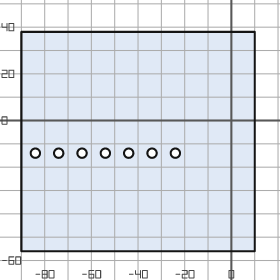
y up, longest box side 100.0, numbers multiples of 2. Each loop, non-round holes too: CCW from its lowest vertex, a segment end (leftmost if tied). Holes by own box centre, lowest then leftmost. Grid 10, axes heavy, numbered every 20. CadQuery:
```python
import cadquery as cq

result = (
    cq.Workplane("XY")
    .moveTo(-90.0, -56.0)
    .lineTo(10.0, -56.0)
    .lineTo(10.0, 38.0)
    .lineTo(-90.0, 38.0)
    .close()
    .moveTo(-84.0, -14.0)
    .circle(2.0)
    .moveTo(-74.0, -14.0)
    .circle(2.0)
    .moveTo(-64.0, -14.0)
    .circle(2.0)
    .moveTo(-54.0, -14.0)
    .circle(2.0)
    .moveTo(-44.0, -14.0)
    .circle(2.0)
    .moveTo(-34.0, -14.0)
    .circle(2.0)
    .moveTo(-24.0, -14.0)
    .circle(2.0)
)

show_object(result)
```